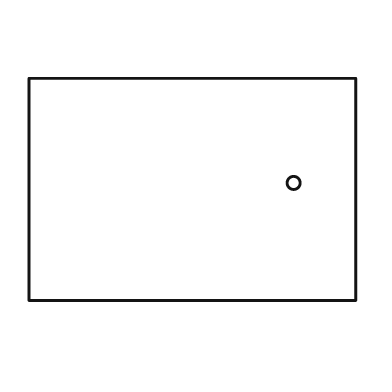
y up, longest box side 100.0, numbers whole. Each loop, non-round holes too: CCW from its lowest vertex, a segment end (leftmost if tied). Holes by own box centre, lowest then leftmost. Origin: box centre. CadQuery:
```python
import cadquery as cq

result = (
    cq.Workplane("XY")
    .moveTo(-50.0, -34.0)
    .lineTo(50.0, -34.0)
    .lineTo(50.0, 34.0)
    .lineTo(-50.0, 34.0)
    .close()
    .moveTo(31.0, 2.0)
    .circle(2.0)
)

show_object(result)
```